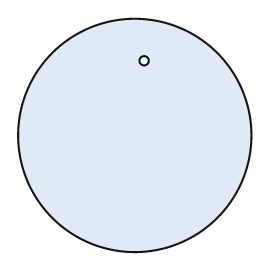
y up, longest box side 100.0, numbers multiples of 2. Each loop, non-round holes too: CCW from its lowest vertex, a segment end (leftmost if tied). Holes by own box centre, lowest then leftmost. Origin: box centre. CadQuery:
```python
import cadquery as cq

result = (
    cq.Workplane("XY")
    .moveTo(0.0, 0.0)
    .circle(50.0)
    .moveTo(4.0, 32.0)
    .circle(2.0)
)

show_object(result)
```